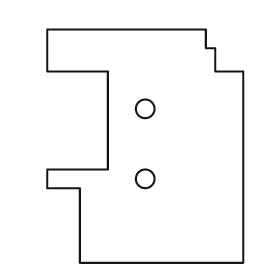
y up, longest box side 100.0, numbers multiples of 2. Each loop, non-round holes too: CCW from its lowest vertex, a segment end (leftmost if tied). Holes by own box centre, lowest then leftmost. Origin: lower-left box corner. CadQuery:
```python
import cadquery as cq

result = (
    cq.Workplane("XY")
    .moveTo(14.0, 0.0)
    .lineTo(84.0, 0.0)
    .lineTo(84.0, 82.0)
    .lineTo(72.0, 82.0)
    .lineTo(72.0, 92.0)
    .lineTo(68.0, 92.0)
    .lineTo(68.0, 100.0)
    .lineTo(0.0, 100.0)
    .lineTo(0.0, 82.0)
    .lineTo(26.0, 82.0)
    .lineTo(26.0, 40.0)
    .lineTo(0.0, 40.0)
    .lineTo(0.0, 32.0)
    .lineTo(14.0, 32.0)
    .close()
    .moveTo(42.0, 36.0)
    .circle(4.0)
    .moveTo(42.0, 66.0)
    .circle(4.0)
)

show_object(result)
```